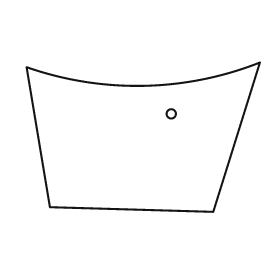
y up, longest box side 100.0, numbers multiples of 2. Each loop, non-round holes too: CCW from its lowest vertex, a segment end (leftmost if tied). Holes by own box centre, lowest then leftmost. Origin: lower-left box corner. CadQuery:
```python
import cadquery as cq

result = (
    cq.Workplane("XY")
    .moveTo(80.0, 0.0)
    .lineTo(100.0, 64.0)
    .threePointArc((50.0, 54.0), (0.0, 62.0))
    .lineTo(10.0, 2.0)
    .close()
    .moveTo(62.0, 42.0)
    .circle(2.0)
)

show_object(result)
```